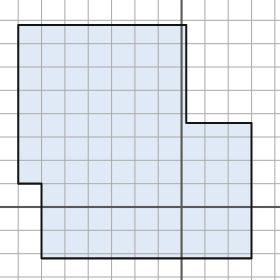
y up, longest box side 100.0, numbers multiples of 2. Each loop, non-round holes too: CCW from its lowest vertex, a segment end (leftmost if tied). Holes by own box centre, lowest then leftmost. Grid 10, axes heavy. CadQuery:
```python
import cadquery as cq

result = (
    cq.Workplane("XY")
    .moveTo(-60.0, -22.0)
    .lineTo(30.0, -22.0)
    .lineTo(30.0, 36.0)
    .lineTo(2.0, 36.0)
    .lineTo(2.0, 78.0)
    .lineTo(-70.0, 78.0)
    .lineTo(-70.0, 10.0)
    .lineTo(-60.0, 10.0)
    .close()
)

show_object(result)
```